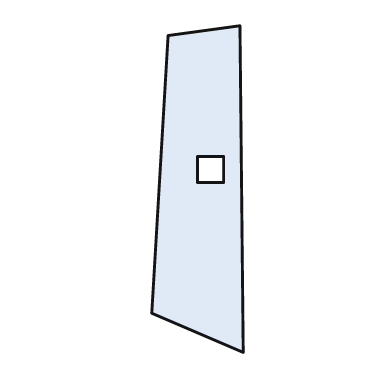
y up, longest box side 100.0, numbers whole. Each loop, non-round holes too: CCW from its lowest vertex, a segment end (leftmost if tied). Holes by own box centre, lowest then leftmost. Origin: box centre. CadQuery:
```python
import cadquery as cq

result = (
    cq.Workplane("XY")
    .moveTo(14.0, -50.0)
    .lineTo(13.0, 50.0)
    .lineTo(-9.0, 47.0)
    .lineTo(-14.0, -38.0)
    .close()
    .moveTo(0.0, 2.0)
    .lineTo(8.0, 2.0)
    .lineTo(8.0, 10.0)
    .lineTo(0.0, 10.0)
    .close()
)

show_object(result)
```